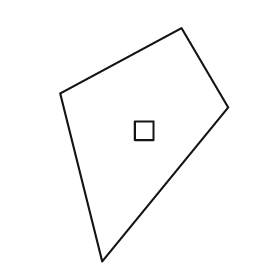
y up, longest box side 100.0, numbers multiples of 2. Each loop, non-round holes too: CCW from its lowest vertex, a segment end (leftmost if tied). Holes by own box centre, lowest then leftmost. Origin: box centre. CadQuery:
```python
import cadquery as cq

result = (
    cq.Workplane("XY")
    .moveTo(-18.0, -50.0)
    .lineTo(36.0, 16.0)
    .lineTo(16.0, 50.0)
    .lineTo(-36.0, 22.0)
    .close()
    .moveTo(-4.0, 2.0)
    .lineTo(4.0, 2.0)
    .lineTo(4.0, 10.0)
    .lineTo(-4.0, 10.0)
    .close()
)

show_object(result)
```